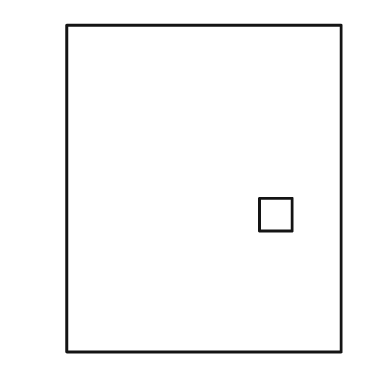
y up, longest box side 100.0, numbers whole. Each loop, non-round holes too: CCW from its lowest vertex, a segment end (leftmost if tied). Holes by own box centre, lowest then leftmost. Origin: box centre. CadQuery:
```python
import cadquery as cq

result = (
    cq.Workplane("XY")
    .moveTo(-42.0, -50.0)
    .lineTo(42.0, -50.0)
    .lineTo(42.0, 50.0)
    .lineTo(-42.0, 50.0)
    .close()
    .moveTo(17.0, -13.0)
    .lineTo(27.0, -13.0)
    .lineTo(27.0, -3.0)
    .lineTo(17.0, -3.0)
    .close()
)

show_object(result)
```